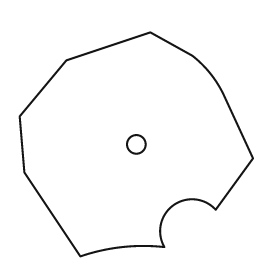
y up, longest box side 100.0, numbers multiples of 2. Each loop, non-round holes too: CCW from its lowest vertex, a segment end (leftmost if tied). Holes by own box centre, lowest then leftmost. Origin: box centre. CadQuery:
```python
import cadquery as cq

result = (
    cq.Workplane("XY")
    .moveTo(-24.0, -48.0)
    .threePointArc((-6.0, -44.0), (12.0, -44.0))
    .threePointArc((16.0, -26.0), (34.0, -28.0))
    .lineTo(50.0, -6.0)
    .lineTo(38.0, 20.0)
    .threePointArc((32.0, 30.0), (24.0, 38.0))
    .lineTo(6.0, 48.0)
    .lineTo(-30.0, 36.0)
    .lineTo(-50.0, 12.0)
    .lineTo(-48.0, -12.0)
    .close()
    .moveTo(0.0, 0.0)
    .circle(4.0)
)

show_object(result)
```